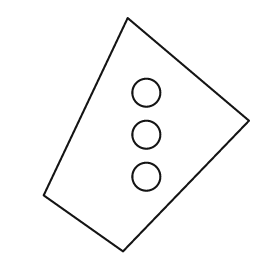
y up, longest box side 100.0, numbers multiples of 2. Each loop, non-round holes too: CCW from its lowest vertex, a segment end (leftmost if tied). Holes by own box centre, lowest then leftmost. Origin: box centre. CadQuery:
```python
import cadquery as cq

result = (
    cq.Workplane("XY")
    .moveTo(-10.0, -50.0)
    .lineTo(44.0, 6.0)
    .lineTo(-8.0, 50.0)
    .lineTo(-44.0, -26.0)
    .close()
    .moveTo(0.0, -18.0)
    .circle(6.0)
    .moveTo(0.0, 0.0)
    .circle(6.0)
    .moveTo(0.0, 18.0)
    .circle(6.0)
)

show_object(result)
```